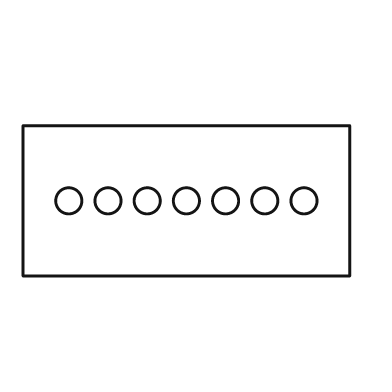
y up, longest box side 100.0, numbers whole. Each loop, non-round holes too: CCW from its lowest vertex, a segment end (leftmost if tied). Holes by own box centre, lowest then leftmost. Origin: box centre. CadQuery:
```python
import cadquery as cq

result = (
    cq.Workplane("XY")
    .moveTo(-50.0, -23.0)
    .lineTo(50.0, -23.0)
    .lineTo(50.0, 23.0)
    .lineTo(-50.0, 23.0)
    .close()
    .moveTo(-36.0, 0.0)
    .circle(4.0)
    .moveTo(-24.0, 0.0)
    .circle(4.0)
    .moveTo(-12.0, 0.0)
    .circle(4.0)
    .moveTo(0.0, 0.0)
    .circle(4.0)
    .moveTo(12.0, 0.0)
    .circle(4.0)
    .moveTo(24.0, 0.0)
    .circle(4.0)
    .moveTo(36.0, 0.0)
    .circle(4.0)
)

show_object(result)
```